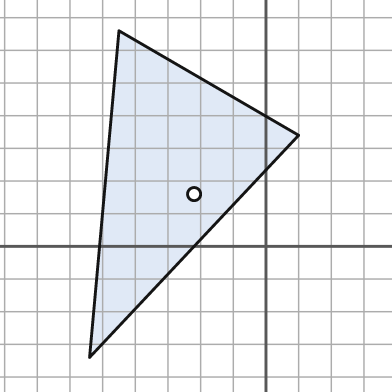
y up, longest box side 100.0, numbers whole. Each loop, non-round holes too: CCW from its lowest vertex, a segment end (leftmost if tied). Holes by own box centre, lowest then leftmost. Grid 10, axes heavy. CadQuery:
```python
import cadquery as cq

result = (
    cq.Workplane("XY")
    .moveTo(-54.0, -34.0)
    .lineTo(10.0, 34.0)
    .lineTo(-45.0, 66.0)
    .close()
    .moveTo(-22.0, 16.0)
    .circle(2.0)
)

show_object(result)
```